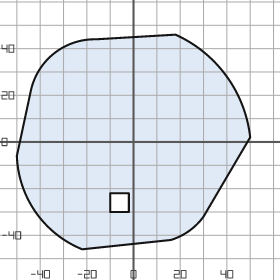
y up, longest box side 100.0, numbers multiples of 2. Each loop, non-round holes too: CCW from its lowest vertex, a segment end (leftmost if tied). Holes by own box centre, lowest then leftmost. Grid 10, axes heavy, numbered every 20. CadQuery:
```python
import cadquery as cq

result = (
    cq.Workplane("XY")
    .moveTo(-22.0, -46.0)
    .lineTo(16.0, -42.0)
    .threePointArc((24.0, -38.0), (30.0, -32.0))
    .lineTo(50.0, 2.0)
    .threePointArc((40.0, 28.0), (18.0, 46.0))
    .lineTo(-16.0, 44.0)
    .threePointArc((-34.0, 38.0), (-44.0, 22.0))
    .lineTo(-50.0, -6.0)
    .threePointArc((-42.0, -30.0), (-22.0, -46.0))
    .close()
    .moveTo(-10.0, -30.0)
    .lineTo(-2.0, -30.0)
    .lineTo(-2.0, -22.0)
    .lineTo(-10.0, -22.0)
    .close()
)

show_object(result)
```